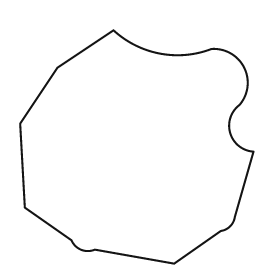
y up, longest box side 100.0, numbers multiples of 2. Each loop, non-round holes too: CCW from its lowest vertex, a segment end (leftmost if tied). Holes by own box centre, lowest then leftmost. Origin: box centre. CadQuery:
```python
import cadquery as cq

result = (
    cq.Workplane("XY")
    .moveTo(16.0, -50.0)
    .lineTo(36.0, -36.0)
    .threePointArc((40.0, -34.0), (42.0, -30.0))
    .lineTo(50.0, -2.0)
    .threePointArc((40.0, 6.0), (44.0, 18.0))
    .threePointArc((46.0, 34.0), (32.0, 42.0))
    .threePointArc((10.0, 40.0), (-10.0, 50.0))
    .lineTo(-34.0, 34.0)
    .lineTo(-50.0, 10.0)
    .lineTo(-48.0, -26.0)
    .lineTo(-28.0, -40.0)
    .threePointArc((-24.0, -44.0), (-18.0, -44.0))
    .close()
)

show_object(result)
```